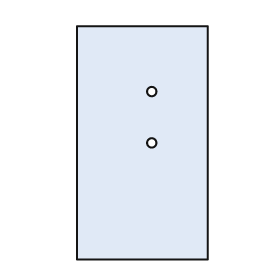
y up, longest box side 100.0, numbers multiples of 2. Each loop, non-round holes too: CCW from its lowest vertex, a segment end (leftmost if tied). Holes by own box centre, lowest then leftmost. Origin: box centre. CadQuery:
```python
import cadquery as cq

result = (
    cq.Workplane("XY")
    .moveTo(-28.0, -50.0)
    .lineTo(28.0, -50.0)
    .lineTo(28.0, 50.0)
    .lineTo(-28.0, 50.0)
    .close()
    .moveTo(4.0, 0.0)
    .circle(2.0)
    .moveTo(4.0, 22.0)
    .circle(2.0)
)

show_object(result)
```